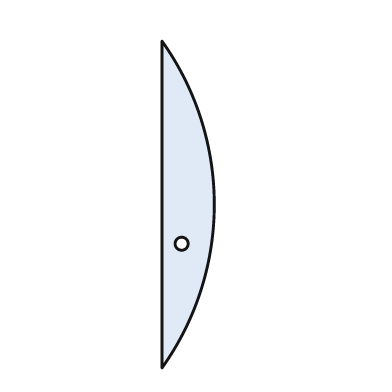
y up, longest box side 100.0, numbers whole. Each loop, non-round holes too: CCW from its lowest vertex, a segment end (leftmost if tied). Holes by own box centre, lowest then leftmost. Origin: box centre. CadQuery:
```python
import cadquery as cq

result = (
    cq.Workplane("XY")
    .moveTo(-8.0, -50.0)
    .threePointArc((8.0, 0.0), (-8.0, 50.0))
    .close()
    .moveTo(-2.0, -12.0)
    .circle(2.0)
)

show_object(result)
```